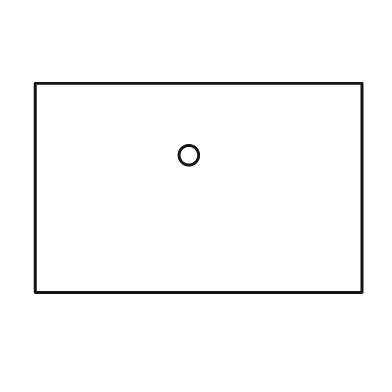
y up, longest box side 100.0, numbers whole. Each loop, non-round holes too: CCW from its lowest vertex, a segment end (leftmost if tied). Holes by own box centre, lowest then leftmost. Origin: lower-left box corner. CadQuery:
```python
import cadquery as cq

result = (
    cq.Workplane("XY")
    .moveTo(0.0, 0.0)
    .lineTo(100.0, 0.0)
    .lineTo(100.0, 64.0)
    .lineTo(0.0, 64.0)
    .close()
    .moveTo(47.0, 42.0)
    .circle(3.0)
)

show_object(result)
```